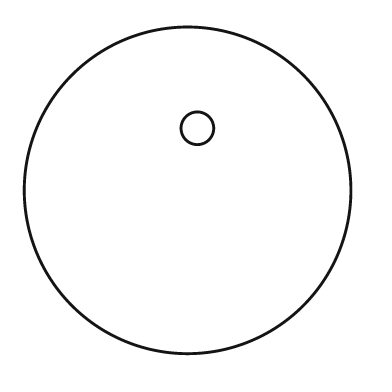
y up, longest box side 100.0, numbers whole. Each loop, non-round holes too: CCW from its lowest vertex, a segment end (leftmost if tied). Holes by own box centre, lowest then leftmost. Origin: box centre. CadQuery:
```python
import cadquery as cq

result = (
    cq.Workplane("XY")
    .moveTo(0.0, 0.0)
    .circle(50.0)
    .moveTo(3.0, 19.0)
    .circle(5.0)
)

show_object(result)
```